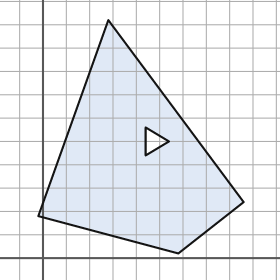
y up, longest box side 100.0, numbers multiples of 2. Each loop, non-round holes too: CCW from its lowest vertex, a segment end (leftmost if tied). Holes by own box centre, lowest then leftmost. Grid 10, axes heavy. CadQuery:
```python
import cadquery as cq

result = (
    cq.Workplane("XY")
    .moveTo(58.0, 2.0)
    .lineTo(86.0, 24.0)
    .lineTo(28.0, 102.0)
    .lineTo(-2.0, 18.0)
    .close()
    .moveTo(44.0, 44.0)
    .lineTo(54.0, 50.0)
    .lineTo(44.0, 56.0)
    .close()
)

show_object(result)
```